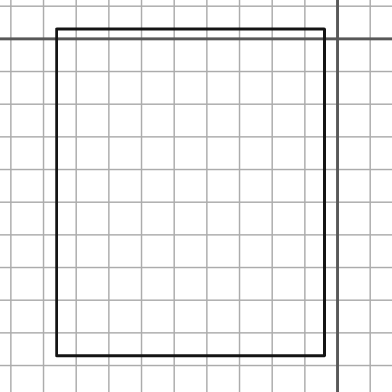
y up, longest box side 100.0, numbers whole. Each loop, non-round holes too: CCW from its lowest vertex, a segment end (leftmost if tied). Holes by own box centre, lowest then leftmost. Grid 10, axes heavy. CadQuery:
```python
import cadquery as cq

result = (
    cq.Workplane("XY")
    .moveTo(-86.0, -97.0)
    .lineTo(-4.0, -97.0)
    .lineTo(-4.0, 3.0)
    .lineTo(-86.0, 3.0)
    .close()
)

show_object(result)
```